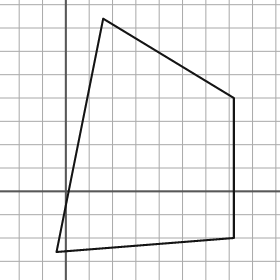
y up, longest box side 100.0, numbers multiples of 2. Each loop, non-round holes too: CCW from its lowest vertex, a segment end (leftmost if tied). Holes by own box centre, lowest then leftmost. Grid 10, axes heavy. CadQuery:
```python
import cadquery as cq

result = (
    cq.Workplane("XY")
    .moveTo(-4.0, -26.0)
    .lineTo(72.0, -20.0)
    .lineTo(72.0, 40.0)
    .lineTo(16.0, 74.0)
    .close()
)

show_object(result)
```